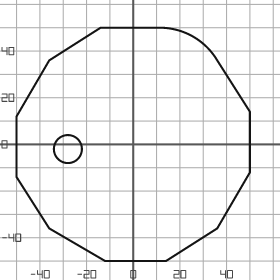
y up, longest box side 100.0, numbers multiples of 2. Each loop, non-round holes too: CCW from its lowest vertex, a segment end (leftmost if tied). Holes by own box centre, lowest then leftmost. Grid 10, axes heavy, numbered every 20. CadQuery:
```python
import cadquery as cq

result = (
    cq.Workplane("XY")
    .moveTo(-12.0, -50.0)
    .lineTo(14.0, -50.0)
    .lineTo(36.0, -36.0)
    .lineTo(50.0, -12.0)
    .lineTo(50.0, 14.0)
    .lineTo(36.0, 36.0)
    .threePointArc((26.0, 46.0), (12.0, 50.0))
    .lineTo(-14.0, 50.0)
    .lineTo(-36.0, 36.0)
    .lineTo(-50.0, 12.0)
    .lineTo(-50.0, -14.0)
    .lineTo(-36.0, -36.0)
    .close()
    .moveTo(-28.0, -2.0)
    .circle(6.0)
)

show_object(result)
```